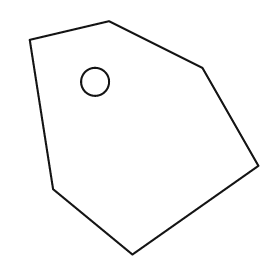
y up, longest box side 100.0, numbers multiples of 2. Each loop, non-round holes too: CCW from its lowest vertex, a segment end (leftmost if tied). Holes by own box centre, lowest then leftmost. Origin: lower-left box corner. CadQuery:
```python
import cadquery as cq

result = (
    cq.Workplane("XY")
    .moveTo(44.0, 0.0)
    .lineTo(98.0, 38.0)
    .lineTo(74.0, 80.0)
    .lineTo(34.0, 100.0)
    .lineTo(0.0, 92.0)
    .lineTo(10.0, 28.0)
    .close()
    .moveTo(28.0, 74.0)
    .circle(6.0)
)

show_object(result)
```